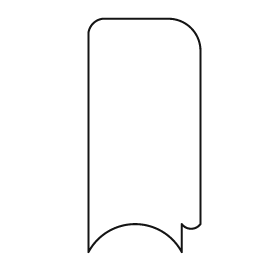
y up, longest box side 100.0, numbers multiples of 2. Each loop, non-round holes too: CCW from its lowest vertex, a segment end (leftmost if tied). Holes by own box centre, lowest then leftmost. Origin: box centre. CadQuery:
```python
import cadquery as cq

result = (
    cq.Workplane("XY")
    .moveTo(-24.0, -50.0)
    .threePointArc((-4.0, -38.0), (16.0, -50.0))
    .lineTo(16.0, -38.0)
    .threePointArc((20.0, -40.0), (24.0, -38.0))
    .lineTo(24.0, 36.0)
    .threePointArc((20.0, 46.0), (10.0, 50.0))
    .lineTo(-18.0, 50.0)
    .threePointArc((-22.0, 48.0), (-24.0, 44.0))
    .close()
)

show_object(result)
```